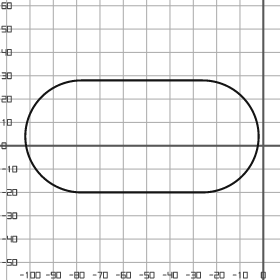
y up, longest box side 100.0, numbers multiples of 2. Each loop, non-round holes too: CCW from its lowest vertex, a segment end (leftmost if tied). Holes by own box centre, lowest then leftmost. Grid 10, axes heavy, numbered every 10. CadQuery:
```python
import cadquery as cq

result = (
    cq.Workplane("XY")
    .moveTo(-78.0, -20.0)
    .lineTo(-26.0, -20.0)
    .threePointArc((-2.0, 4.0), (-26.0, 28.0))
    .lineTo(-78.0, 28.0)
    .threePointArc((-102.0, 4.0), (-78.0, -20.0))
    .close()
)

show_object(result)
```